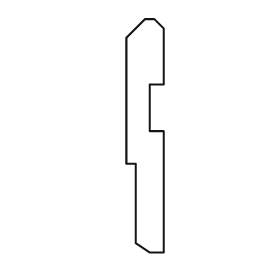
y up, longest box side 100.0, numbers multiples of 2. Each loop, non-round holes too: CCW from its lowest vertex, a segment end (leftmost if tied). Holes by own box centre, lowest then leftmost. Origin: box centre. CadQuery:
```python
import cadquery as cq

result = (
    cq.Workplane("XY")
    .moveTo(2.0, -50.0)
    .lineTo(8.0, -50.0)
    .lineTo(8.0, 2.0)
    .lineTo(2.0, 2.0)
    .lineTo(2.0, 22.0)
    .lineTo(8.0, 22.0)
    .lineTo(8.0, 46.0)
    .lineTo(4.0, 50.0)
    .lineTo(0.0, 50.0)
    .lineTo(-8.0, 42.0)
    .lineTo(-8.0, -12.0)
    .lineTo(-4.0, -12.0)
    .lineTo(-4.0, -46.0)
    .close()
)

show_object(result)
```